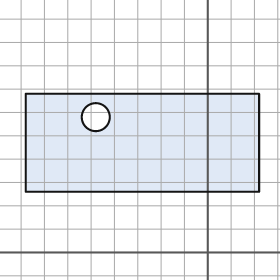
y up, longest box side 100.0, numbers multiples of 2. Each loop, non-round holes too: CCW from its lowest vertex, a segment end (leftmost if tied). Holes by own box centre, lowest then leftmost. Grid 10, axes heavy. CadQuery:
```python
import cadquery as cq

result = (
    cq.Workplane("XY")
    .moveTo(-78.0, 26.0)
    .lineTo(22.0, 26.0)
    .lineTo(22.0, 68.0)
    .lineTo(-78.0, 68.0)
    .close()
    .moveTo(-48.0, 58.0)
    .circle(6.0)
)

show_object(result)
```